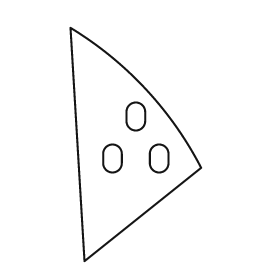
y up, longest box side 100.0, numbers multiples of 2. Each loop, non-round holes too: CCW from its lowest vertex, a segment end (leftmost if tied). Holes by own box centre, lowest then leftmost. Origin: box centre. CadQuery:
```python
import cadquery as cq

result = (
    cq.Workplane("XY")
    .moveTo(-22.0, -50.0)
    .lineTo(28.0, -10.0)
    .threePointArc((4.0, 24.0), (-28.0, 50.0))
    .close()
    .moveTo(-14.0, -8.0)
    .threePointArc((-10.0, -12.0), (-6.0, -8.0))
    .lineTo(-6.0, -4.0)
    .threePointArc((-10.0, 0.0), (-14.0, -4.0))
    .close()
    .moveTo(6.0, -8.0)
    .threePointArc((10.0, -12.0), (14.0, -8.0))
    .lineTo(14.0, -4.0)
    .threePointArc((10.0, 0.0), (6.0, -4.0))
    .close()
    .moveTo(-4.0, 10.0)
    .threePointArc((0.0, 6.0), (4.0, 10.0))
    .lineTo(4.0, 14.0)
    .threePointArc((0.0, 18.0), (-4.0, 14.0))
    .close()
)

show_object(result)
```